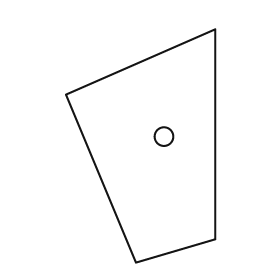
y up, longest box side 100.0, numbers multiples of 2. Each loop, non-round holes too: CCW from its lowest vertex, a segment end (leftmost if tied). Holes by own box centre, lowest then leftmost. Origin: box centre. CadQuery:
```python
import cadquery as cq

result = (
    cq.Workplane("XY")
    .moveTo(-2.0, -50.0)
    .lineTo(32.0, -40.0)
    .lineTo(32.0, 50.0)
    .lineTo(-32.0, 22.0)
    .close()
    .moveTo(10.0, 4.0)
    .circle(4.0)
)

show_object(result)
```